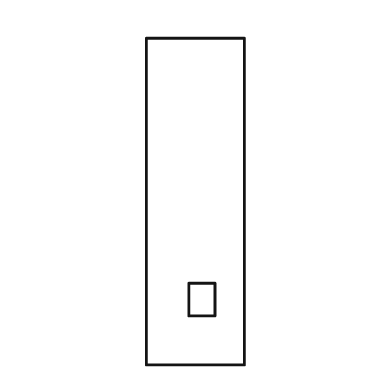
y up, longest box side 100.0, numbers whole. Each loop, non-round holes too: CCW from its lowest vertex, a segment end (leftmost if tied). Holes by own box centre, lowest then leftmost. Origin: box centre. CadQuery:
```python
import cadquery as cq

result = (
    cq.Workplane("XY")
    .moveTo(-15.0, -50.0)
    .lineTo(15.0, -50.0)
    .lineTo(15.0, 50.0)
    .lineTo(-15.0, 50.0)
    .close()
    .moveTo(-2.0, -35.0)
    .lineTo(6.0, -35.0)
    .lineTo(6.0, -25.0)
    .lineTo(-2.0, -25.0)
    .close()
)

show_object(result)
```